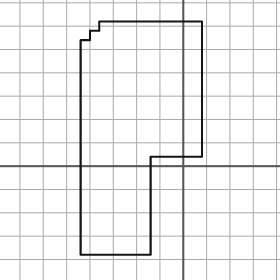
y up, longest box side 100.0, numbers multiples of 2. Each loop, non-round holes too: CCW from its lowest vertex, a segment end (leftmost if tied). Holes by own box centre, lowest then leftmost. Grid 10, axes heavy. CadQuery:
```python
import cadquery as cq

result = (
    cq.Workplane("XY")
    .moveTo(-44.0, -38.0)
    .lineTo(-14.0, -38.0)
    .lineTo(-14.0, 4.0)
    .lineTo(8.0, 4.0)
    .lineTo(8.0, 62.0)
    .lineTo(-36.0, 62.0)
    .lineTo(-36.0, 58.0)
    .lineTo(-40.0, 58.0)
    .lineTo(-40.0, 54.0)
    .lineTo(-44.0, 54.0)
    .close()
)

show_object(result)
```